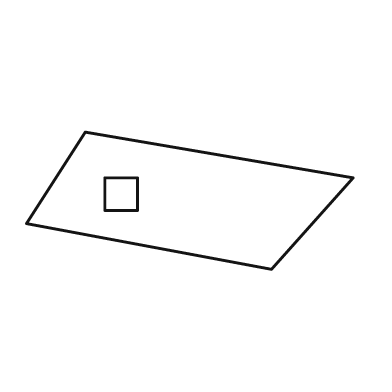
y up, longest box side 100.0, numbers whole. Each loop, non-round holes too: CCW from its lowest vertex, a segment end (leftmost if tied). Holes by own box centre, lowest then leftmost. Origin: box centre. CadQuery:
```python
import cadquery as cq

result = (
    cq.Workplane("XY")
    .moveTo(25.0, -21.0)
    .lineTo(50.0, 7.0)
    .lineTo(-32.0, 21.0)
    .lineTo(-50.0, -7.0)
    .close()
    .moveTo(-26.0, -3.0)
    .lineTo(-16.0, -3.0)
    .lineTo(-16.0, 7.0)
    .lineTo(-26.0, 7.0)
    .close()
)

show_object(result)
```